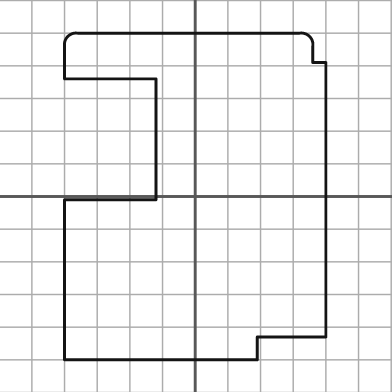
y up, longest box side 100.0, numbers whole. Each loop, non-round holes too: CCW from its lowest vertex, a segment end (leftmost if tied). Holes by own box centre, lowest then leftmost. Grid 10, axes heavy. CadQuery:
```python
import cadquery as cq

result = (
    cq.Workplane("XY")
    .moveTo(-40.0, -50.0)
    .lineTo(19.0, -50.0)
    .lineTo(19.0, -43.0)
    .lineTo(40.0, -43.0)
    .lineTo(40.0, 41.0)
    .lineTo(36.0, 41.0)
    .lineTo(36.0, 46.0)
    .threePointArc((35.0, 49.0), (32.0, 50.0))
    .lineTo(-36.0, 50.0)
    .threePointArc((-39.0, 49.0), (-40.0, 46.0))
    .lineTo(-40.0, 36.0)
    .lineTo(-12.0, 36.0)
    .lineTo(-12.0, -1.0)
    .lineTo(-40.0, -1.0)
    .close()
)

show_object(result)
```